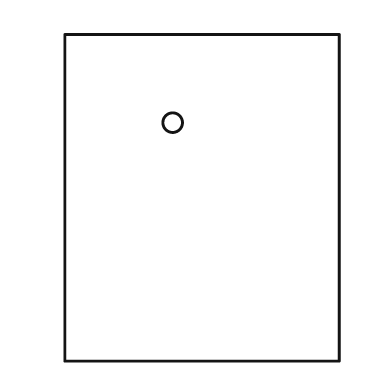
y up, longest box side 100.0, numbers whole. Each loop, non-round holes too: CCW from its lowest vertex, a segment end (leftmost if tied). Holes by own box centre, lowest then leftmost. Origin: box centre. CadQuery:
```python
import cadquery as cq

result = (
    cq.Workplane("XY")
    .moveTo(-42.0, -50.0)
    .lineTo(42.0, -50.0)
    .lineTo(42.0, 50.0)
    .lineTo(-42.0, 50.0)
    .close()
    .moveTo(-9.0, 23.0)
    .circle(3.0)
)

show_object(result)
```